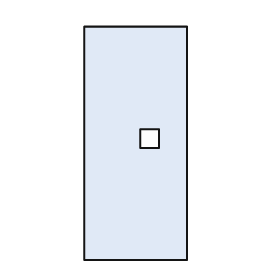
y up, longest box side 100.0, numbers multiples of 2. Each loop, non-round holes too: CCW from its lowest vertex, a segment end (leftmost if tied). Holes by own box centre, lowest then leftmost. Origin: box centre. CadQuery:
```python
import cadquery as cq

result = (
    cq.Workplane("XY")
    .moveTo(-22.0, -50.0)
    .lineTo(22.0, -50.0)
    .lineTo(22.0, 50.0)
    .lineTo(-22.0, 50.0)
    .close()
    .moveTo(2.0, -2.0)
    .lineTo(10.0, -2.0)
    .lineTo(10.0, 6.0)
    .lineTo(2.0, 6.0)
    .close()
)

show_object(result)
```